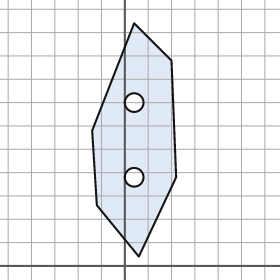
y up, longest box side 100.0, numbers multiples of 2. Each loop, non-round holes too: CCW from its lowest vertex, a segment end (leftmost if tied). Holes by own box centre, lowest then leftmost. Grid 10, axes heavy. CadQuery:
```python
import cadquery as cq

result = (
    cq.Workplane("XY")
    .moveTo(6.0, 4.0)
    .lineTo(22.0, 38.0)
    .lineTo(20.0, 88.0)
    .lineTo(4.0, 104.0)
    .lineTo(-14.0, 58.0)
    .lineTo(-12.0, 26.0)
    .close()
    .moveTo(4.0, 38.0)
    .circle(4.0)
    .moveTo(4.0, 70.0)
    .circle(4.0)
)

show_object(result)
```